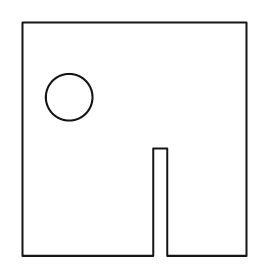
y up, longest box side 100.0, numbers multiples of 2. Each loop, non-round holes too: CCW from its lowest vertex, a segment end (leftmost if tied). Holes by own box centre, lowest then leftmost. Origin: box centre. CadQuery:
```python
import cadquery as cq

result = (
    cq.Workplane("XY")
    .moveTo(-48.0, -50.0)
    .lineTo(8.0, -50.0)
    .lineTo(8.0, -4.0)
    .lineTo(14.0, -4.0)
    .lineTo(14.0, -50.0)
    .lineTo(48.0, -50.0)
    .lineTo(48.0, 50.0)
    .lineTo(-48.0, 50.0)
    .close()
    .moveTo(-28.0, 18.0)
    .circle(10.0)
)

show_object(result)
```